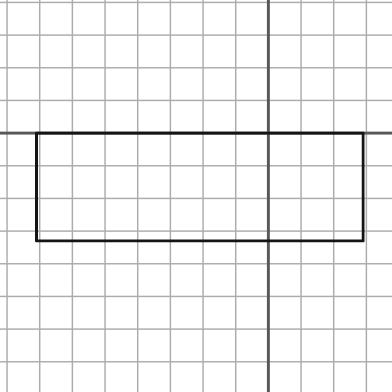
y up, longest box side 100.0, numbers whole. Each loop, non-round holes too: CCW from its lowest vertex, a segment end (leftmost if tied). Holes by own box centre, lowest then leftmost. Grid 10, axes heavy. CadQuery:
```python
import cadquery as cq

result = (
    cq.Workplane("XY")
    .moveTo(-71.0, -33.0)
    .lineTo(29.0, -33.0)
    .lineTo(29.0, 0.0)
    .lineTo(-71.0, 0.0)
    .close()
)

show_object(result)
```